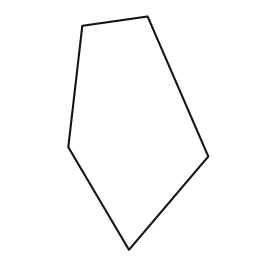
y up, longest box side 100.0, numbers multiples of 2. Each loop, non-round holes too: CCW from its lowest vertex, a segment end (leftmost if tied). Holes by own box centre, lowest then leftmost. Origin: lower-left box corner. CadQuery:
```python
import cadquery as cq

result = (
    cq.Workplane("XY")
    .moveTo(26.0, 0.0)
    .lineTo(60.0, 40.0)
    .lineTo(34.0, 100.0)
    .lineTo(6.0, 96.0)
    .lineTo(0.0, 44.0)
    .close()
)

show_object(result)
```